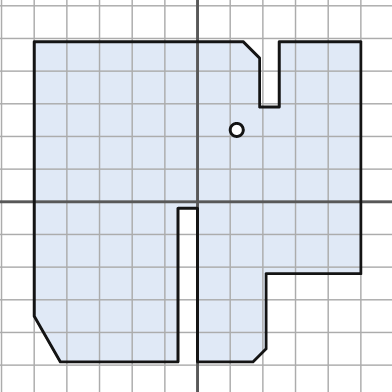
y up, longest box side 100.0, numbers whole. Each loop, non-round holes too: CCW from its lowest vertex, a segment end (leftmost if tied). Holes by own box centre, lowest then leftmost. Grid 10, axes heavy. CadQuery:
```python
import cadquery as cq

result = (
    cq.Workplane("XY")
    .moveTo(-42.0, -49.0)
    .lineTo(-6.0, -49.0)
    .lineTo(-6.0, -2.0)
    .lineTo(0.0, -2.0)
    .lineTo(0.0, -49.0)
    .lineTo(17.0, -49.0)
    .lineTo(21.0, -45.0)
    .lineTo(21.0, -22.0)
    .lineTo(50.0, -22.0)
    .lineTo(50.0, 49.0)
    .lineTo(25.0, 49.0)
    .lineTo(25.0, 29.0)
    .lineTo(19.0, 29.0)
    .lineTo(19.0, 44.0)
    .lineTo(14.0, 49.0)
    .lineTo(-50.0, 49.0)
    .lineTo(-50.0, -35.0)
    .close()
    .moveTo(12.0, 22.0)
    .circle(2.0)
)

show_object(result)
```